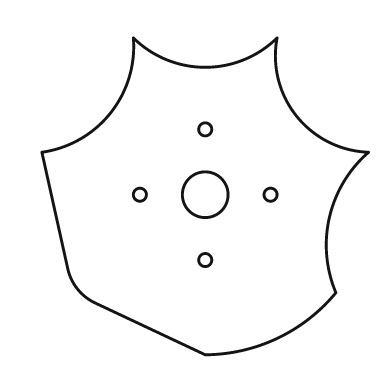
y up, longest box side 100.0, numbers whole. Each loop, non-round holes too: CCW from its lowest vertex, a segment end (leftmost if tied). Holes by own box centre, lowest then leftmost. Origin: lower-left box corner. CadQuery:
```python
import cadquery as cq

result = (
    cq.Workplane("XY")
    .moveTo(50.0, 0.0)
    .threePointArc((72.0, 5.0), (90.0, 19.0))
    .threePointArc((88.0, 42.0), (100.0, 62.0))
    .threePointArc((78.0, 73.0), (72.0, 97.0))
    .threePointArc((50.0, 88.0), (28.0, 97.0))
    .threePointArc((21.0, 74.0), (0.0, 62.0))
    .lineTo(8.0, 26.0)
    .threePointArc((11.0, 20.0), (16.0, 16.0))
    .close()
    .moveTo(50.0, 29.0)
    .circle(2.0)
    .moveTo(30.0, 49.0)
    .circle(2.0)
    .moveTo(50.0, 49.0)
    .circle(7.0)
    .moveTo(70.0, 49.0)
    .circle(2.0)
    .moveTo(50.0, 69.0)
    .circle(2.0)
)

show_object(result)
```